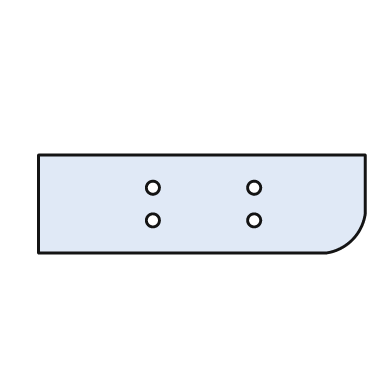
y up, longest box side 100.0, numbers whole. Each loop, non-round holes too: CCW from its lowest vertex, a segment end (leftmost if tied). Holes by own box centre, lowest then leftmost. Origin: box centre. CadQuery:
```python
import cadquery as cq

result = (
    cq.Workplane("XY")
    .moveTo(-50.0, -15.0)
    .lineTo(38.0, -15.0)
    .threePointArc((46.0, -11.0), (50.0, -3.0))
    .lineTo(50.0, 15.0)
    .lineTo(-50.0, 15.0)
    .close()
    .moveTo(-15.0, -5.0)
    .circle(2.0)
    .moveTo(16.0, -5.0)
    .circle(2.0)
    .moveTo(-15.0, 5.0)
    .circle(2.0)
    .moveTo(16.0, 5.0)
    .circle(2.0)
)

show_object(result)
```